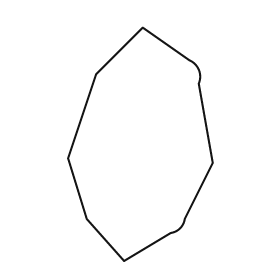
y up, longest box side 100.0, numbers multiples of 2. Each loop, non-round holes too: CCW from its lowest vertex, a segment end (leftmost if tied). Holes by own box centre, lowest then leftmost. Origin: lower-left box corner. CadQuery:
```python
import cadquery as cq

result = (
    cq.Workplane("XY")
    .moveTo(24.0, 0.0)
    .lineTo(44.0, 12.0)
    .threePointArc((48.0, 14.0), (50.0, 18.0))
    .lineTo(62.0, 42.0)
    .lineTo(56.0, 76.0)
    .threePointArc((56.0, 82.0), (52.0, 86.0))
    .lineTo(32.0, 100.0)
    .lineTo(12.0, 80.0)
    .lineTo(0.0, 44.0)
    .lineTo(8.0, 18.0)
    .close()
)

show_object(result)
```